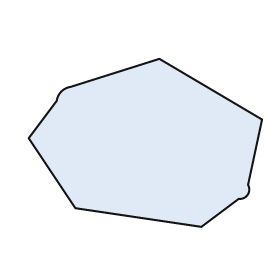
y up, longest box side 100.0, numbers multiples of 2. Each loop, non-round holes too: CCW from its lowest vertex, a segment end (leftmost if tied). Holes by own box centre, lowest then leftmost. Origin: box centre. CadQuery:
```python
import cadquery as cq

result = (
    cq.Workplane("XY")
    .moveTo(24.0, -36.0)
    .lineTo(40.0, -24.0)
    .threePointArc((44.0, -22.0), (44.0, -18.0))
    .lineTo(50.0, 10.0)
    .lineTo(6.0, 36.0)
    .lineTo(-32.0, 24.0)
    .threePointArc((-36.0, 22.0), (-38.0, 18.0))
    .lineTo(-50.0, 2.0)
    .lineTo(-30.0, -28.0)
    .close()
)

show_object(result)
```